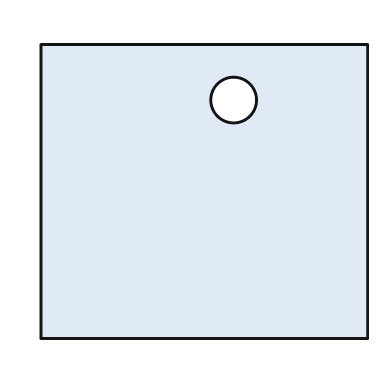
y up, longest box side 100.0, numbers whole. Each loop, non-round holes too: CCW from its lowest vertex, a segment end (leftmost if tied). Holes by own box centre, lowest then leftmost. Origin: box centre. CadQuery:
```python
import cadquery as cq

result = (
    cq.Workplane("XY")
    .moveTo(-50.0, -45.0)
    .lineTo(50.0, -45.0)
    .lineTo(50.0, 45.0)
    .lineTo(-50.0, 45.0)
    .close()
    .moveTo(9.0, 28.0)
    .circle(7.0)
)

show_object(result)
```